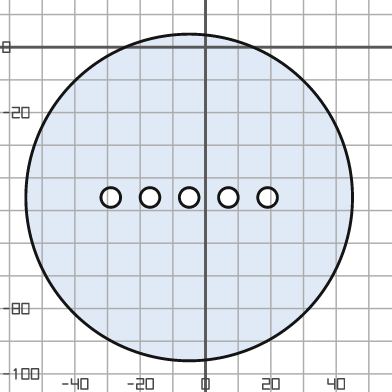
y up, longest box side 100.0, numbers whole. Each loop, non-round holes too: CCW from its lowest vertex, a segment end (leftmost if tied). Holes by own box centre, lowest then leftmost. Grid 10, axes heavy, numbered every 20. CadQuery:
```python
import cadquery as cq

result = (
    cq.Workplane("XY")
    .moveTo(-5.0, -46.0)
    .circle(50.0)
    .moveTo(-29.0, -46.0)
    .circle(3.0)
    .moveTo(-17.0, -46.0)
    .circle(3.0)
    .moveTo(-5.0, -46.0)
    .circle(3.0)
    .moveTo(7.0, -46.0)
    .circle(3.0)
    .moveTo(19.0, -46.0)
    .circle(3.0)
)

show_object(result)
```